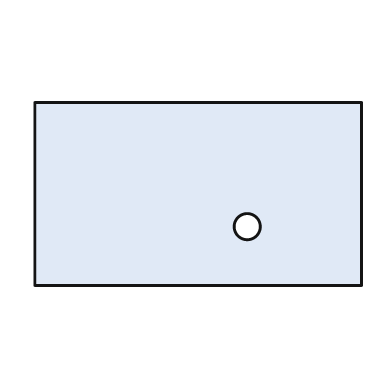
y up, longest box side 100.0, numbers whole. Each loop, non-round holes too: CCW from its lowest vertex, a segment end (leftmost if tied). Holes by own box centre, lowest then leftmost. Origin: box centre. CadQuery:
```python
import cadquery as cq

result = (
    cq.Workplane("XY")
    .moveTo(-50.0, -28.0)
    .lineTo(50.0, -28.0)
    .lineTo(50.0, 28.0)
    .lineTo(-50.0, 28.0)
    .close()
    .moveTo(15.0, -10.0)
    .circle(4.0)
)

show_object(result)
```